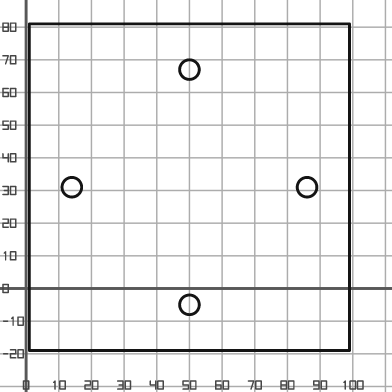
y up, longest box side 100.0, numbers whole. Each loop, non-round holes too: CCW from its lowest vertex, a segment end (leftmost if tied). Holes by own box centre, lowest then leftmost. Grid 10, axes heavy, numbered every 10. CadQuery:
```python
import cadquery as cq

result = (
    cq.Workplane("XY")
    .moveTo(1.0, -19.0)
    .lineTo(99.0, -19.0)
    .lineTo(99.0, 81.0)
    .lineTo(1.0, 81.0)
    .close()
    .moveTo(50.0, -5.0)
    .circle(3.0)
    .moveTo(14.0, 31.0)
    .circle(3.0)
    .moveTo(86.0, 31.0)
    .circle(3.0)
    .moveTo(50.0, 67.0)
    .circle(3.0)
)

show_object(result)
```